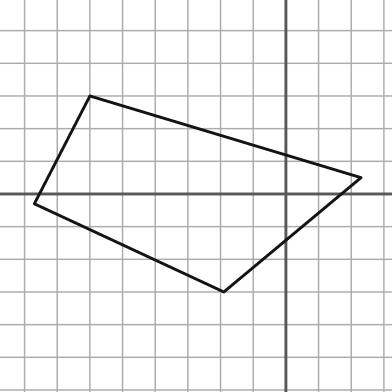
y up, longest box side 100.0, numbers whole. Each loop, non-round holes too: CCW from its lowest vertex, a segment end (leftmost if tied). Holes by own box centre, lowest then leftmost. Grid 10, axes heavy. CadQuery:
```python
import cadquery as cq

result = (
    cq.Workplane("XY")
    .moveTo(-19.0, -30.0)
    .lineTo(23.0, 5.0)
    .lineTo(-60.0, 30.0)
    .lineTo(-77.0, -3.0)
    .close()
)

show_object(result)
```